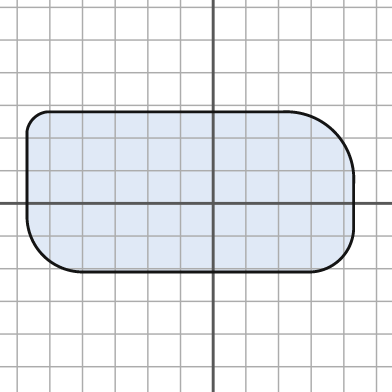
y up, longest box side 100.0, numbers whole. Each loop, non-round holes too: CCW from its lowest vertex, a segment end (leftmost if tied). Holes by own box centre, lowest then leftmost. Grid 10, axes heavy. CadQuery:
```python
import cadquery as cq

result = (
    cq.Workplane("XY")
    .moveTo(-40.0, -21.0)
    .lineTo(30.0, -21.0)
    .threePointArc((39.0, -17.0), (43.0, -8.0))
    .lineTo(43.0, 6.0)
    .threePointArc((37.0, 22.0), (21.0, 28.0))
    .lineTo(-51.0, 28.0)
    .threePointArc((-55.0, 26.0), (-57.0, 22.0))
    .lineTo(-57.0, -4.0)
    .threePointArc((-52.0, -16.0), (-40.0, -21.0))
    .close()
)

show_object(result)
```